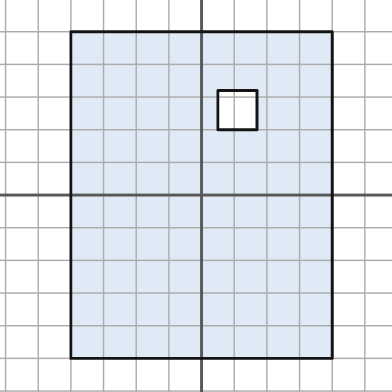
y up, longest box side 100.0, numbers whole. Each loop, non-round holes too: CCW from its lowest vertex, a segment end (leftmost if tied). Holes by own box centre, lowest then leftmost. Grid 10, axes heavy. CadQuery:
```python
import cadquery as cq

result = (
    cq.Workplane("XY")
    .moveTo(-40.0, -50.0)
    .lineTo(40.0, -50.0)
    .lineTo(40.0, 50.0)
    .lineTo(-40.0, 50.0)
    .close()
    .moveTo(5.0, 20.0)
    .lineTo(17.0, 20.0)
    .lineTo(17.0, 32.0)
    .lineTo(5.0, 32.0)
    .close()
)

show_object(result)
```